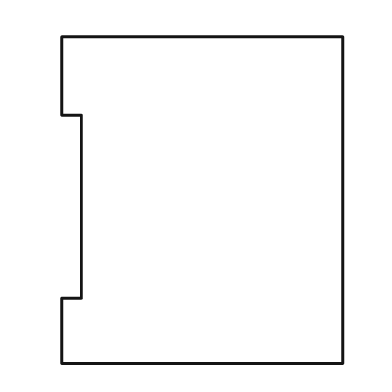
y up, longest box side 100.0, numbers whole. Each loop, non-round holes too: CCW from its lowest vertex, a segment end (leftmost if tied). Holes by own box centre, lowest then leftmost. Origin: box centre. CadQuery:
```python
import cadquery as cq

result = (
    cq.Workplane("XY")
    .moveTo(-43.0, -50.0)
    .lineTo(43.0, -50.0)
    .lineTo(43.0, 50.0)
    .lineTo(-43.0, 50.0)
    .lineTo(-43.0, 26.0)
    .lineTo(-37.0, 26.0)
    .lineTo(-37.0, -30.0)
    .lineTo(-43.0, -30.0)
    .close()
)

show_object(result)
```